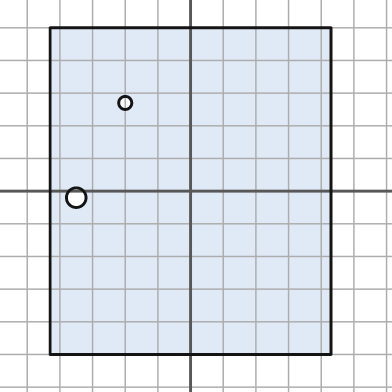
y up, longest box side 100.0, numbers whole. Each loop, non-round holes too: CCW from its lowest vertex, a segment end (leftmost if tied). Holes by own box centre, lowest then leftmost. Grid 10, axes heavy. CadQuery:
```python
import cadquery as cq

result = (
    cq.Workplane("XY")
    .moveTo(-43.0, -50.0)
    .lineTo(43.0, -50.0)
    .lineTo(43.0, 50.0)
    .lineTo(-43.0, 50.0)
    .close()
    .moveTo(-35.0, -2.0)
    .circle(3.0)
    .moveTo(-20.0, 27.0)
    .circle(2.0)
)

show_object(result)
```